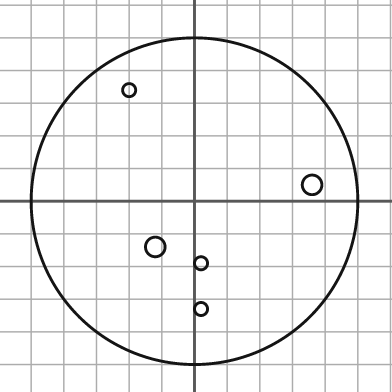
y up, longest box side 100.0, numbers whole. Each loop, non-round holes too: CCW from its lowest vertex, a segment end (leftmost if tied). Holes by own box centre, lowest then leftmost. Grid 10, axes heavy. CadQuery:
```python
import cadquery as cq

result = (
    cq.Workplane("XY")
    .moveTo(0.0, 0.0)
    .circle(50.0)
    .moveTo(2.0, -33.0)
    .circle(2.0)
    .moveTo(2.0, -19.0)
    .circle(2.0)
    .moveTo(-12.0, -14.0)
    .circle(3.0)
    .moveTo(36.0, 5.0)
    .circle(3.0)
    .moveTo(-20.0, 34.0)
    .circle(2.0)
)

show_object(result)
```